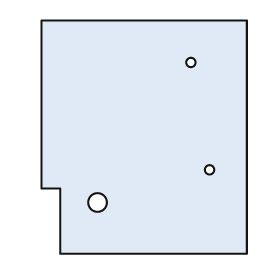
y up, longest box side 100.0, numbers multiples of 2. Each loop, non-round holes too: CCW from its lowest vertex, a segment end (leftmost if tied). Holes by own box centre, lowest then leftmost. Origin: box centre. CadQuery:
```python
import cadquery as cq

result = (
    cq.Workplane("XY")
    .moveTo(-36.0, -50.0)
    .lineTo(44.0, -50.0)
    .lineTo(44.0, 50.0)
    .lineTo(-44.0, 50.0)
    .lineTo(-44.0, -22.0)
    .lineTo(-36.0, -22.0)
    .close()
    .moveTo(-20.0, -28.0)
    .circle(4.0)
    .moveTo(28.0, -14.0)
    .circle(2.0)
    .moveTo(20.0, 32.0)
    .circle(2.0)
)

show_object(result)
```